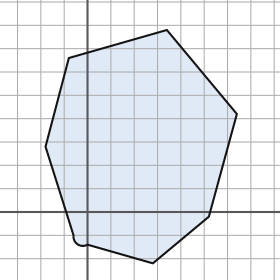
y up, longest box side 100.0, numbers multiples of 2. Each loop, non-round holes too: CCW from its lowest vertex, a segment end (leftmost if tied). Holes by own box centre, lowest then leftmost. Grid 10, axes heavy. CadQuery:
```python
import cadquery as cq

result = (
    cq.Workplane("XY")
    .moveTo(28.0, -22.0)
    .lineTo(52.0, -2.0)
    .lineTo(64.0, 42.0)
    .lineTo(34.0, 78.0)
    .lineTo(-8.0, 66.0)
    .lineTo(-18.0, 28.0)
    .lineTo(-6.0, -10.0)
    .threePointArc((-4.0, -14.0), (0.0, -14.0))
    .close()
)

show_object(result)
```